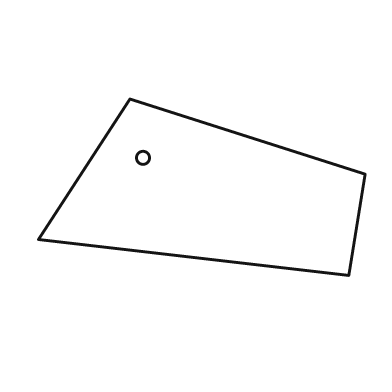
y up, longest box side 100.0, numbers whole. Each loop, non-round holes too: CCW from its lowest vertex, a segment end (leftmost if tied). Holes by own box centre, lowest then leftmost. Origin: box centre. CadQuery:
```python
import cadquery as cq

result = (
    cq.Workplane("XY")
    .moveTo(45.0, -27.0)
    .lineTo(50.0, 4.0)
    .lineTo(-22.0, 27.0)
    .lineTo(-50.0, -16.0)
    .close()
    .moveTo(-18.0, 9.0)
    .circle(2.0)
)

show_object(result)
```